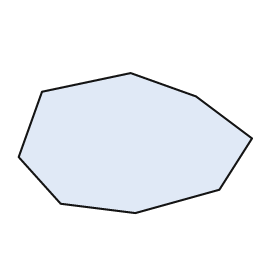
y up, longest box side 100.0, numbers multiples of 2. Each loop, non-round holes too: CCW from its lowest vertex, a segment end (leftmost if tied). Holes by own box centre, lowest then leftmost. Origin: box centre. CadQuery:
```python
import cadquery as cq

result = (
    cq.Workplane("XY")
    .moveTo(0.0, -30.0)
    .lineTo(36.0, -20.0)
    .lineTo(50.0, 2.0)
    .lineTo(26.0, 20.0)
    .lineTo(-2.0, 30.0)
    .lineTo(-40.0, 22.0)
    .lineTo(-50.0, -6.0)
    .lineTo(-32.0, -26.0)
    .close()
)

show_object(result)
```